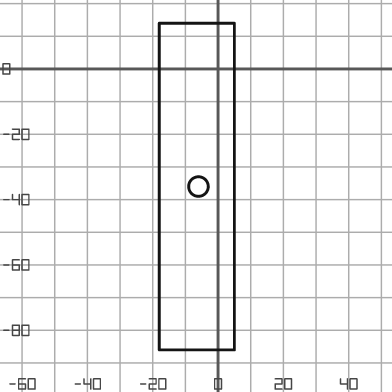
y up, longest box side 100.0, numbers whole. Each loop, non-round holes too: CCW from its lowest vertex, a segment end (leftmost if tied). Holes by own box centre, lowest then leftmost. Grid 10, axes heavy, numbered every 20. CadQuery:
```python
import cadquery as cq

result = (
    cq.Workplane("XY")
    .moveTo(-18.0, -86.0)
    .lineTo(5.0, -86.0)
    .lineTo(5.0, 14.0)
    .lineTo(-18.0, 14.0)
    .close()
    .moveTo(-6.0, -36.0)
    .circle(3.0)
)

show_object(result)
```